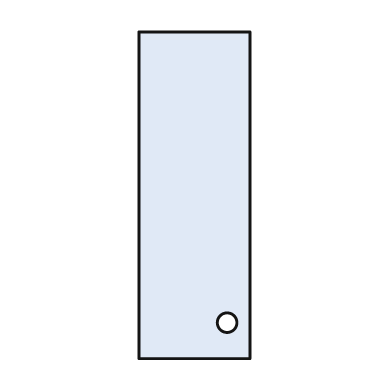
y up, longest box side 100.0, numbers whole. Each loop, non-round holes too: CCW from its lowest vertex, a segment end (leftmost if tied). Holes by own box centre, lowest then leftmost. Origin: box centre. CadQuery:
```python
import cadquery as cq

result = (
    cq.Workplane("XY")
    .moveTo(-17.0, -50.0)
    .lineTo(17.0, -50.0)
    .lineTo(17.0, 50.0)
    .lineTo(-17.0, 50.0)
    .close()
    .moveTo(10.0, -39.0)
    .circle(3.0)
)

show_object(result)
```